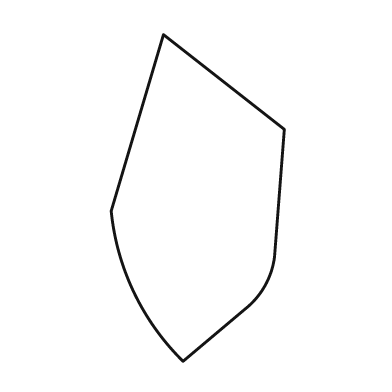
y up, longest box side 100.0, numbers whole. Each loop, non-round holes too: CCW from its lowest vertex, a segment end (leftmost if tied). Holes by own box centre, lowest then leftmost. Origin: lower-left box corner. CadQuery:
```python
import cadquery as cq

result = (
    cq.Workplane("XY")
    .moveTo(22.0, 0.0)
    .lineTo(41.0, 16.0)
    .threePointArc((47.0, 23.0), (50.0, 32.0))
    .lineTo(53.0, 71.0)
    .lineTo(16.0, 100.0)
    .lineTo(0.0, 46.0)
    .threePointArc((7.0, 21.0), (22.0, 0.0))
    .close()
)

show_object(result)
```